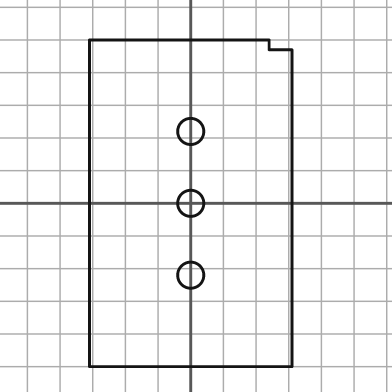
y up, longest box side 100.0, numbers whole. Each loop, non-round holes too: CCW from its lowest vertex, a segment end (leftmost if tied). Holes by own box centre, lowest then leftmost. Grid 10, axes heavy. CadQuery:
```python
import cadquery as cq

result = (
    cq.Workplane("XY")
    .moveTo(-31.0, -50.0)
    .lineTo(31.0, -50.0)
    .lineTo(31.0, 47.0)
    .lineTo(24.0, 47.0)
    .lineTo(24.0, 50.0)
    .lineTo(-31.0, 50.0)
    .close()
    .moveTo(0.0, -22.0)
    .circle(4.0)
    .moveTo(0.0, 0.0)
    .circle(4.0)
    .moveTo(0.0, 22.0)
    .circle(4.0)
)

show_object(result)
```